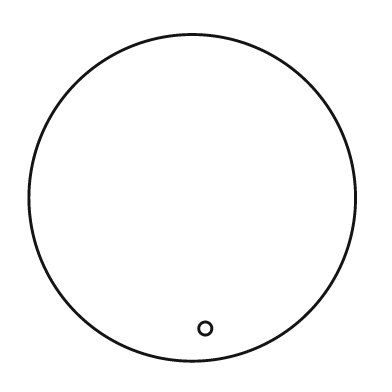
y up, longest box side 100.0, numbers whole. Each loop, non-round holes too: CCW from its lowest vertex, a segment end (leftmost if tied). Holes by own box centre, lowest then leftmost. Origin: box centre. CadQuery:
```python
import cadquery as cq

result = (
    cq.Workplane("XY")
    .moveTo(0.0, 0.0)
    .circle(50.0)
    .moveTo(4.0, -40.0)
    .circle(2.0)
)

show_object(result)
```